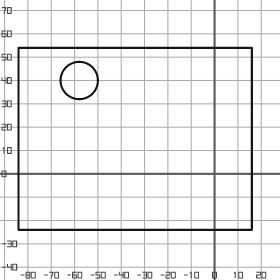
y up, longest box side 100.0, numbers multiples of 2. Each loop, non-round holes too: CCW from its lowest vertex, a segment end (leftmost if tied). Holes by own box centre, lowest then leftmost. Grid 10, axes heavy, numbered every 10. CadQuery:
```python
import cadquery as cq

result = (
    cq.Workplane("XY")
    .moveTo(-84.0, -24.0)
    .lineTo(16.0, -24.0)
    .lineTo(16.0, 54.0)
    .lineTo(-84.0, 54.0)
    .close()
    .moveTo(-58.0, 40.0)
    .circle(8.0)
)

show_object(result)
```